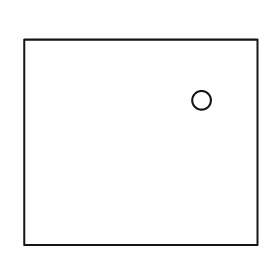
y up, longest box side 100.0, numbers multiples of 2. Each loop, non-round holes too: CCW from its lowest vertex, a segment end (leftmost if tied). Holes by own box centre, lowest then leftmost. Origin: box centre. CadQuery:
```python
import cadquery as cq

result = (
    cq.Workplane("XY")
    .moveTo(-50.0, -44.0)
    .lineTo(50.0, -44.0)
    .lineTo(50.0, 44.0)
    .lineTo(-50.0, 44.0)
    .close()
    .moveTo(26.0, 18.0)
    .circle(4.0)
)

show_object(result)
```